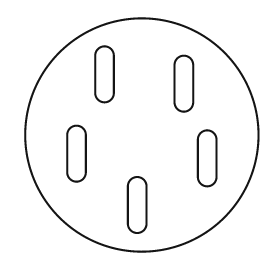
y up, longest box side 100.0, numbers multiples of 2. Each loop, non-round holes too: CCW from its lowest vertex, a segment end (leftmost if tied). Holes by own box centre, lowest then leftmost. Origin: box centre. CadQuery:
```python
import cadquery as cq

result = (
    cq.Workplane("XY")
    .moveTo(0.0, 0.0)
    .circle(50.0)
    .moveTo(-6.0, -38.0)
    .threePointArc((-2.0, -42.0), (2.0, -38.0))
    .lineTo(2.0, -22.0)
    .threePointArc((-2.0, -18.0), (-6.0, -22.0))
    .close()
    .moveTo(24.0, -18.0)
    .threePointArc((28.0, -22.0), (32.0, -18.0))
    .lineTo(32.0, -2.0)
    .threePointArc((28.0, 2.0), (24.0, -2.0))
    .close()
    .moveTo(-32.0, -16.0)
    .threePointArc((-28.0, -20.0), (-24.0, -16.0))
    .lineTo(-24.0, 0.0)
    .threePointArc((-28.0, 4.0), (-32.0, 0.0))
    .close()
    .moveTo(14.0, 14.0)
    .threePointArc((18.0, 10.0), (22.0, 14.0))
    .lineTo(22.0, 30.0)
    .threePointArc((18.0, 34.0), (14.0, 30.0))
    .close()
    .moveTo(-20.0, 18.0)
    .threePointArc((-16.0, 14.0), (-12.0, 18.0))
    .lineTo(-12.0, 34.0)
    .threePointArc((-16.0, 38.0), (-20.0, 34.0))
    .close()
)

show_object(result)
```